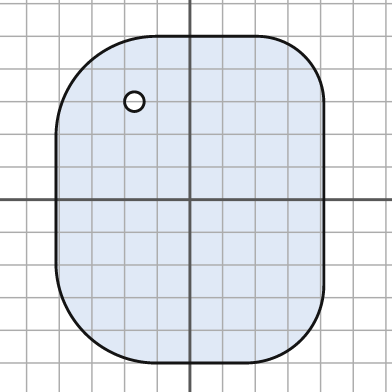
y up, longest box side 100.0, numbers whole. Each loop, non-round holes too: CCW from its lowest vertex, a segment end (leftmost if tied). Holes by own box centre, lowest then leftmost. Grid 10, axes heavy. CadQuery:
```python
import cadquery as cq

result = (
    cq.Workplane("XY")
    .moveTo(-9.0, -50.0)
    .lineTo(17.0, -50.0)
    .threePointArc((34.0, -43.0), (41.0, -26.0))
    .lineTo(41.0, 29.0)
    .threePointArc((35.0, 44.0), (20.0, 50.0))
    .lineTo(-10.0, 50.0)
    .threePointArc((-32.0, 41.0), (-41.0, 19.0))
    .lineTo(-41.0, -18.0)
    .threePointArc((-32.0, -41.0), (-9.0, -50.0))
    .close()
    .moveTo(-17.0, 30.0)
    .circle(3.0)
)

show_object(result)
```